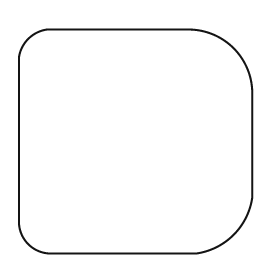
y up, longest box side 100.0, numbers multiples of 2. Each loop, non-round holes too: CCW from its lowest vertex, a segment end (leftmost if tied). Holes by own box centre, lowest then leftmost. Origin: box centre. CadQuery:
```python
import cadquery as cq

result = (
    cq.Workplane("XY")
    .moveTo(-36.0, -48.0)
    .lineTo(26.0, -48.0)
    .threePointArc((42.0, -40.0), (50.0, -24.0))
    .lineTo(50.0, 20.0)
    .threePointArc((42.0, 40.0), (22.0, 48.0))
    .lineTo(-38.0, 48.0)
    .threePointArc((-46.0, 44.0), (-50.0, 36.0))
    .lineTo(-50.0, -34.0)
    .threePointArc((-46.0, -44.0), (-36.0, -48.0))
    .close()
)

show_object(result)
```